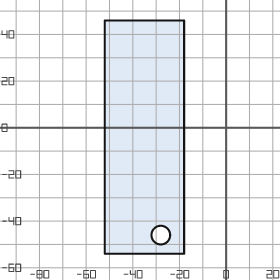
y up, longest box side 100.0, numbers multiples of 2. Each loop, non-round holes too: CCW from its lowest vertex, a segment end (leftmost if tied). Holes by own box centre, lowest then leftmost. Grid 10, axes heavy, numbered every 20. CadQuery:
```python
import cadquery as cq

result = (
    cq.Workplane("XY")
    .moveTo(-52.0, -54.0)
    .lineTo(-18.0, -54.0)
    .lineTo(-18.0, 46.0)
    .lineTo(-52.0, 46.0)
    .close()
    .moveTo(-28.0, -46.0)
    .circle(4.0)
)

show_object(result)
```